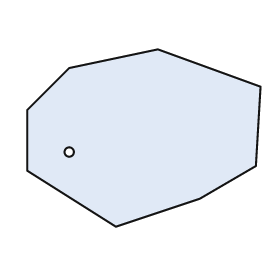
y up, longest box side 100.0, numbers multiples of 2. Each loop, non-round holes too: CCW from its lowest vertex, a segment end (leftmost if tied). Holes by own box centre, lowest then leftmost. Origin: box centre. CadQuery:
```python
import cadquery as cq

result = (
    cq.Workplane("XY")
    .moveTo(-12.0, -38.0)
    .lineTo(24.0, -26.0)
    .lineTo(48.0, -12.0)
    .lineTo(50.0, 22.0)
    .lineTo(6.0, 38.0)
    .lineTo(-32.0, 30.0)
    .lineTo(-50.0, 12.0)
    .lineTo(-50.0, -14.0)
    .close()
    .moveTo(-32.0, -6.0)
    .circle(2.0)
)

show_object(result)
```